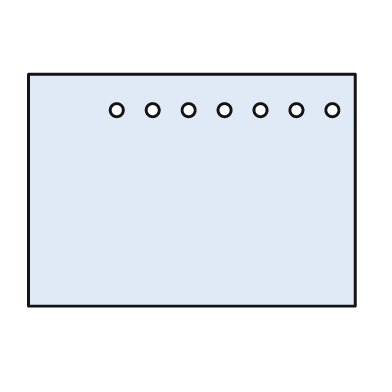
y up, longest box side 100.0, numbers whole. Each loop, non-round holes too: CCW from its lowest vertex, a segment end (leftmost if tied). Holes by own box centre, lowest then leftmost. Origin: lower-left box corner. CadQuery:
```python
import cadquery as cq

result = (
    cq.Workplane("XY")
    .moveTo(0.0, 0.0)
    .lineTo(100.0, 0.0)
    .lineTo(100.0, 71.0)
    .lineTo(0.0, 71.0)
    .close()
    .moveTo(27.0, 60.0)
    .circle(2.0)
    .moveTo(38.0, 60.0)
    .circle(2.0)
    .moveTo(49.0, 60.0)
    .circle(2.0)
    .moveTo(60.0, 60.0)
    .circle(2.0)
    .moveTo(71.0, 60.0)
    .circle(2.0)
    .moveTo(82.0, 60.0)
    .circle(2.0)
    .moveTo(93.0, 60.0)
    .circle(2.0)
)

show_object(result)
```